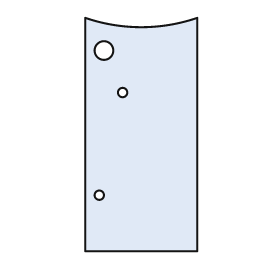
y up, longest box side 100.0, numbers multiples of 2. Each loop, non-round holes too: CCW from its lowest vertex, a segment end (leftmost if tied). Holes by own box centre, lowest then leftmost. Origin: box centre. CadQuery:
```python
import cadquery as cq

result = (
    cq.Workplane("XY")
    .moveTo(-24.0, -50.0)
    .lineTo(24.0, -50.0)
    .lineTo(24.0, 50.0)
    .threePointArc((0.0, 46.0), (-24.0, 50.0))
    .close()
    .moveTo(-18.0, -26.0)
    .circle(2.0)
    .moveTo(-8.0, 18.0)
    .circle(2.0)
    .moveTo(-16.0, 36.0)
    .circle(4.0)
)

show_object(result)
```